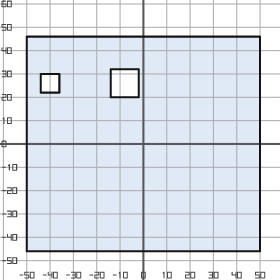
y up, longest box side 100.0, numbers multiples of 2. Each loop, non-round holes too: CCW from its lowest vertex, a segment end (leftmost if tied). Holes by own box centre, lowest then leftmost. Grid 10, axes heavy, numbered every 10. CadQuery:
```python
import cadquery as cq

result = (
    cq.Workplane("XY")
    .moveTo(-50.0, -46.0)
    .lineTo(50.0, -46.0)
    .lineTo(50.0, 46.0)
    .lineTo(-50.0, 46.0)
    .close()
    .moveTo(-44.0, 22.0)
    .lineTo(-36.0, 22.0)
    .lineTo(-36.0, 30.0)
    .lineTo(-44.0, 30.0)
    .close()
    .moveTo(-14.0, 20.0)
    .lineTo(-2.0, 20.0)
    .lineTo(-2.0, 32.0)
    .lineTo(-14.0, 32.0)
    .close()
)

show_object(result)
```